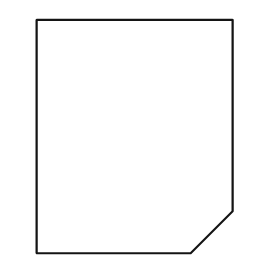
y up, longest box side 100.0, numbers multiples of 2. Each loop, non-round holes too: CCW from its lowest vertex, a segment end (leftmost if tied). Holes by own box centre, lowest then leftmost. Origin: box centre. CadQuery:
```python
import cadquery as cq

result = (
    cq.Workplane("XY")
    .moveTo(-42.0, -50.0)
    .lineTo(24.0, -50.0)
    .lineTo(42.0, -32.0)
    .lineTo(42.0, 50.0)
    .lineTo(-42.0, 50.0)
    .close()
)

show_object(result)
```